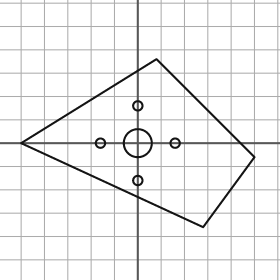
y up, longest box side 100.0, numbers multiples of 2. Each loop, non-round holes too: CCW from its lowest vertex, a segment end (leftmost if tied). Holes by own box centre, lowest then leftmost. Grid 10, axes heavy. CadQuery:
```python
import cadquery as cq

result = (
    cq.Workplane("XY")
    .moveTo(28.0, -36.0)
    .lineTo(50.0, -6.0)
    .lineTo(8.0, 36.0)
    .lineTo(-50.0, 0.0)
    .close()
    .moveTo(0.0, -16.0)
    .circle(2.0)
    .moveTo(-16.0, 0.0)
    .circle(2.0)
    .moveTo(0.0, 0.0)
    .circle(6.0)
    .moveTo(16.0, 0.0)
    .circle(2.0)
    .moveTo(0.0, 16.0)
    .circle(2.0)
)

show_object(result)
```